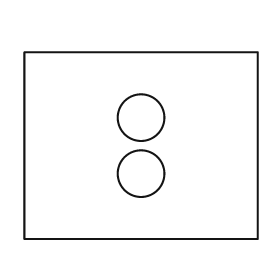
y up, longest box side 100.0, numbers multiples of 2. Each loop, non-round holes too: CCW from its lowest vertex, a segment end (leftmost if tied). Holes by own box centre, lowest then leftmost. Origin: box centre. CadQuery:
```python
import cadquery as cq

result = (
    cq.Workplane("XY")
    .moveTo(-50.0, -40.0)
    .lineTo(50.0, -40.0)
    .lineTo(50.0, 40.0)
    .lineTo(-50.0, 40.0)
    .close()
    .moveTo(0.0, -12.0)
    .circle(10.0)
    .moveTo(0.0, 12.0)
    .circle(10.0)
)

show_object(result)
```